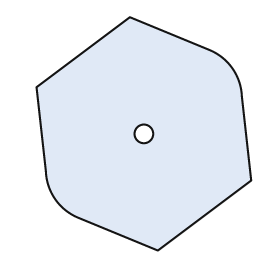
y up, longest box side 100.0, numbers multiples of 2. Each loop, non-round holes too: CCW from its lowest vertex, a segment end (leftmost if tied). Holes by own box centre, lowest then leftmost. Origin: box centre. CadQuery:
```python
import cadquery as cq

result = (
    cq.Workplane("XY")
    .moveTo(6.0, -50.0)
    .lineTo(46.0, -20.0)
    .lineTo(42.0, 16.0)
    .threePointArc((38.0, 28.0), (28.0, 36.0))
    .lineTo(-6.0, 50.0)
    .lineTo(-46.0, 20.0)
    .lineTo(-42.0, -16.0)
    .threePointArc((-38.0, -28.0), (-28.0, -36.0))
    .close()
    .moveTo(0.0, 0.0)
    .circle(4.0)
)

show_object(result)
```